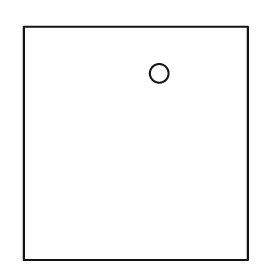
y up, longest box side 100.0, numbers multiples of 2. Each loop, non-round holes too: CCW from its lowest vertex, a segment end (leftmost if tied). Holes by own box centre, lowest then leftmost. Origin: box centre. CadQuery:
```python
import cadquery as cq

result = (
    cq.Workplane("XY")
    .moveTo(-48.0, -50.0)
    .lineTo(48.0, -50.0)
    .lineTo(48.0, 50.0)
    .lineTo(-48.0, 50.0)
    .close()
    .moveTo(10.0, 30.0)
    .circle(4.0)
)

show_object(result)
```